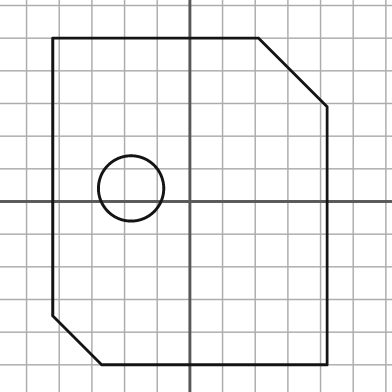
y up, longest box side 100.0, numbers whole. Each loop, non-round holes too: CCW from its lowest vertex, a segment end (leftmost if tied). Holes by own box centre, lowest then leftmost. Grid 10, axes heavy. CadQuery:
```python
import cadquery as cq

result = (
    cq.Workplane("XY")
    .moveTo(-27.0, -50.0)
    .lineTo(42.0, -50.0)
    .lineTo(42.0, 29.0)
    .lineTo(21.0, 50.0)
    .lineTo(-42.0, 50.0)
    .lineTo(-42.0, -35.0)
    .close()
    .moveTo(-18.0, 4.0)
    .circle(10.0)
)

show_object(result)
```